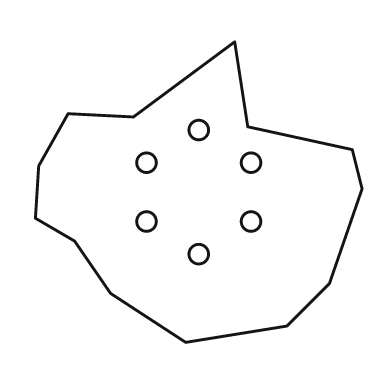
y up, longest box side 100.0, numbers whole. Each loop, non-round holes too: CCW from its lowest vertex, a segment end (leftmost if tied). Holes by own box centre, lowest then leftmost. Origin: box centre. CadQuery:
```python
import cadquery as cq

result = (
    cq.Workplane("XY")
    .moveTo(-4.0, -46.0)
    .lineTo(27.0, -41.0)
    .lineTo(40.0, -28.0)
    .lineTo(50.0, 1.0)
    .lineTo(47.0, 13.0)
    .lineTo(15.0, 20.0)
    .lineTo(11.0, 46.0)
    .lineTo(-20.0, 23.0)
    .lineTo(-40.0, 24.0)
    .lineTo(-49.0, 8.0)
    .lineTo(-50.0, -8.0)
    .lineTo(-38.0, -15.0)
    .lineTo(-27.0, -31.0)
    .close()
    .moveTo(0.0, -19.0)
    .circle(3.0)
    .moveTo(-16.0, -9.0)
    .circle(3.0)
    .moveTo(16.0, -9.0)
    .circle(3.0)
    .moveTo(-16.0, 9.0)
    .circle(3.0)
    .moveTo(16.0, 9.0)
    .circle(3.0)
    .moveTo(0.0, 19.0)
    .circle(3.0)
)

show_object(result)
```